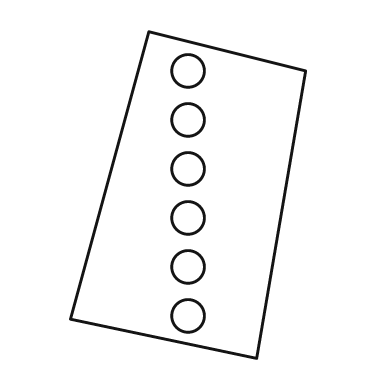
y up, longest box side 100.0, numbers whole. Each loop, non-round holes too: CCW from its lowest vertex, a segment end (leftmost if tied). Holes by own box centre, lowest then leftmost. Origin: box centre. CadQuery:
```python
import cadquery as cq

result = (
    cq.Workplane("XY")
    .moveTo(21.0, -50.0)
    .lineTo(36.0, 38.0)
    .lineTo(-12.0, 50.0)
    .lineTo(-36.0, -38.0)
    .close()
    .moveTo(0.0, -37.0)
    .circle(5.0)
    .moveTo(0.0, -22.0)
    .circle(5.0)
    .moveTo(0.0, -7.0)
    .circle(5.0)
    .moveTo(0.0, 8.0)
    .circle(5.0)
    .moveTo(0.0, 23.0)
    .circle(5.0)
    .moveTo(0.0, 38.0)
    .circle(5.0)
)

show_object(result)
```